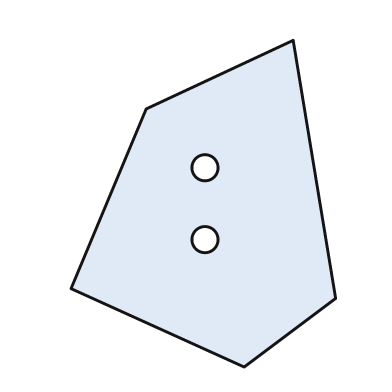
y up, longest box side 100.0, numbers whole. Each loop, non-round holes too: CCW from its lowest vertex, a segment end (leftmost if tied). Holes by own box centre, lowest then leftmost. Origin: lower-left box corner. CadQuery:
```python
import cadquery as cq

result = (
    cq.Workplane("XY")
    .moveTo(53.0, 0.0)
    .lineTo(81.0, 21.0)
    .lineTo(68.0, 100.0)
    .lineTo(23.0, 79.0)
    .lineTo(0.0, 24.0)
    .close()
    .moveTo(41.0, 39.0)
    .circle(4.0)
    .moveTo(41.0, 61.0)
    .circle(4.0)
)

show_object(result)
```